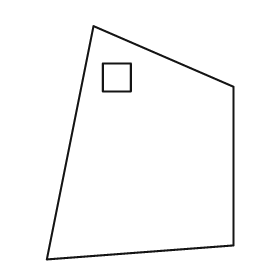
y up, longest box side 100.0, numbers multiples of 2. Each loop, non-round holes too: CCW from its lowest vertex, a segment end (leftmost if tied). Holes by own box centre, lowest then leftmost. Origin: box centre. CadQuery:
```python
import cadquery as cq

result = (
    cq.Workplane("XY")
    .moveTo(-40.0, -50.0)
    .lineTo(40.0, -44.0)
    .lineTo(40.0, 24.0)
    .lineTo(-20.0, 50.0)
    .close()
    .moveTo(-16.0, 22.0)
    .lineTo(-4.0, 22.0)
    .lineTo(-4.0, 34.0)
    .lineTo(-16.0, 34.0)
    .close()
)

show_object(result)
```